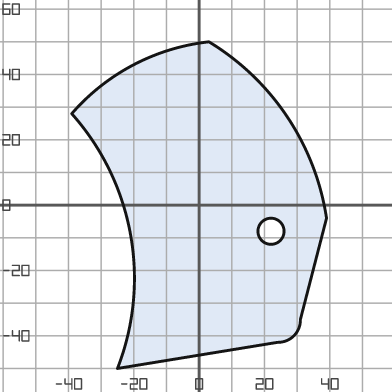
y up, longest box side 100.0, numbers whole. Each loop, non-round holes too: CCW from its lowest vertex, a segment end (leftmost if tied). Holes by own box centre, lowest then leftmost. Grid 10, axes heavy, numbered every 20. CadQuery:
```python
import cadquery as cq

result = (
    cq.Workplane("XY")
    .moveTo(-25.0, -50.0)
    .lineTo(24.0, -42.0)
    .threePointArc((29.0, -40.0), (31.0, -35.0))
    .lineTo(39.0, -4.0)
    .threePointArc((27.0, 27.0), (3.0, 50.0))
    .threePointArc((-20.0, 43.0), (-39.0, 28.0))
    .threePointArc((-21.0, -9.0), (-25.0, -50.0))
    .close()
    .moveTo(22.0, -8.0)
    .circle(4.0)
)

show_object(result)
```